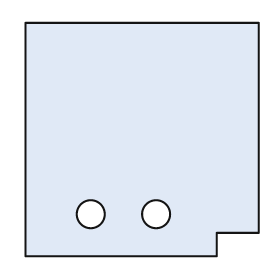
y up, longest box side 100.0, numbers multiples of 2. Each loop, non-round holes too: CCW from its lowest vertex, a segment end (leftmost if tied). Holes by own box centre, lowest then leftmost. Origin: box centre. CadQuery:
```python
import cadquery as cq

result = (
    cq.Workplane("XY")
    .moveTo(-50.0, -50.0)
    .lineTo(32.0, -50.0)
    .lineTo(32.0, -40.0)
    .lineTo(50.0, -40.0)
    .lineTo(50.0, 50.0)
    .lineTo(-50.0, 50.0)
    .close()
    .moveTo(-22.0, -32.0)
    .circle(6.0)
    .moveTo(6.0, -32.0)
    .circle(6.0)
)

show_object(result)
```